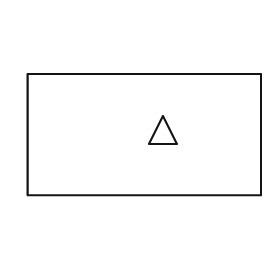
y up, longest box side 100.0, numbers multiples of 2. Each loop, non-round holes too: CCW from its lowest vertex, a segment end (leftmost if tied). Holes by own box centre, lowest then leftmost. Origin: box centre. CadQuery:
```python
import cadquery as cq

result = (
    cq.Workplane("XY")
    .moveTo(-50.0, -26.0)
    .lineTo(50.0, -26.0)
    .lineTo(50.0, 26.0)
    .lineTo(-50.0, 26.0)
    .close()
    .moveTo(2.0, -4.0)
    .lineTo(14.0, -4.0)
    .lineTo(8.0, 8.0)
    .close()
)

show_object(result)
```